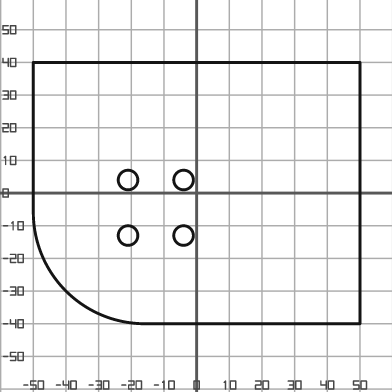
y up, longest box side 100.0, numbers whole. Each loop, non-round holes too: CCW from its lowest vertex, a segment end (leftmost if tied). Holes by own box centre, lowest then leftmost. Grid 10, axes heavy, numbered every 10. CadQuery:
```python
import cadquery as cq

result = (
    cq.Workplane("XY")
    .moveTo(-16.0, -40.0)
    .lineTo(50.0, -40.0)
    .lineTo(50.0, 40.0)
    .lineTo(-50.0, 40.0)
    .lineTo(-50.0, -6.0)
    .threePointArc((-40.0, -30.0), (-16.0, -40.0))
    .close()
    .moveTo(-21.0, -13.0)
    .circle(3.0)
    .moveTo(-4.0, -13.0)
    .circle(3.0)
    .moveTo(-21.0, 4.0)
    .circle(3.0)
    .moveTo(-4.0, 4.0)
    .circle(3.0)
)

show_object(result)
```